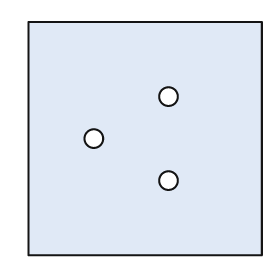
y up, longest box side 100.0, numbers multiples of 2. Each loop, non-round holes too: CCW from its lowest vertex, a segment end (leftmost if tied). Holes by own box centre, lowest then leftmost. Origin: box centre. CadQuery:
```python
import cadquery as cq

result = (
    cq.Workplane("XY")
    .moveTo(-50.0, -50.0)
    .lineTo(50.0, -50.0)
    .lineTo(50.0, 50.0)
    .lineTo(-50.0, 50.0)
    .close()
    .moveTo(10.0, -18.0)
    .circle(4.0)
    .moveTo(-22.0, 0.0)
    .circle(4.0)
    .moveTo(10.0, 18.0)
    .circle(4.0)
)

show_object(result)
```